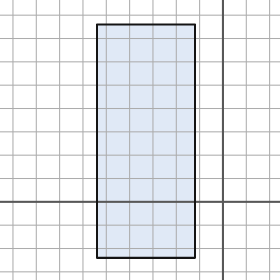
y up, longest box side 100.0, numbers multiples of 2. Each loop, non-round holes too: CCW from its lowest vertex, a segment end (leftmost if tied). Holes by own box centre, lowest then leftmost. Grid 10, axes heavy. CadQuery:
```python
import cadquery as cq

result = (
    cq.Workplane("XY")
    .moveTo(-54.0, -24.0)
    .lineTo(-12.0, -24.0)
    .lineTo(-12.0, 76.0)
    .lineTo(-54.0, 76.0)
    .close()
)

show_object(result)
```